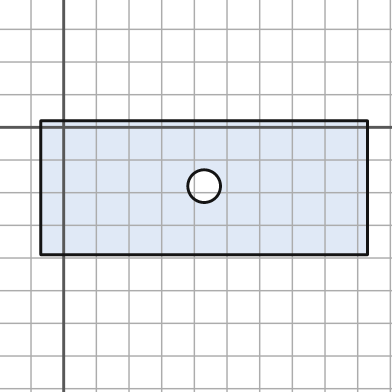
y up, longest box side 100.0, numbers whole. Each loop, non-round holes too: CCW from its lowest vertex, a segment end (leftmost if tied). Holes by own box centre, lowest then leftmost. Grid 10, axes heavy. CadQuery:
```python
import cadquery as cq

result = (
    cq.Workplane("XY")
    .moveTo(-7.0, -39.0)
    .lineTo(93.0, -39.0)
    .lineTo(93.0, 2.0)
    .lineTo(-7.0, 2.0)
    .close()
    .moveTo(43.0, -18.0)
    .circle(5.0)
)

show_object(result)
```